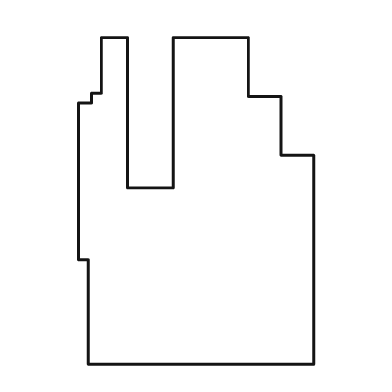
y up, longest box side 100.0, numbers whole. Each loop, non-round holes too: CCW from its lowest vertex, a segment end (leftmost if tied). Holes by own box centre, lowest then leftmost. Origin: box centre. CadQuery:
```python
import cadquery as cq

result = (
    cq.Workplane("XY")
    .moveTo(-33.0, -50.0)
    .lineTo(36.0, -50.0)
    .lineTo(36.0, 14.0)
    .lineTo(26.0, 14.0)
    .lineTo(26.0, 32.0)
    .lineTo(16.0, 32.0)
    .lineTo(16.0, 50.0)
    .lineTo(-7.0, 50.0)
    .lineTo(-7.0, 4.0)
    .lineTo(-21.0, 4.0)
    .lineTo(-21.0, 50.0)
    .lineTo(-29.0, 50.0)
    .lineTo(-29.0, 33.0)
    .lineTo(-32.0, 33.0)
    .lineTo(-32.0, 30.0)
    .lineTo(-36.0, 30.0)
    .lineTo(-36.0, -18.0)
    .lineTo(-33.0, -18.0)
    .close()
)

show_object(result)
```